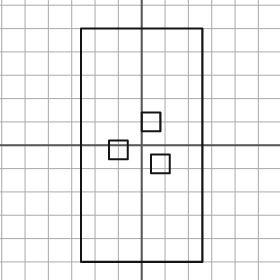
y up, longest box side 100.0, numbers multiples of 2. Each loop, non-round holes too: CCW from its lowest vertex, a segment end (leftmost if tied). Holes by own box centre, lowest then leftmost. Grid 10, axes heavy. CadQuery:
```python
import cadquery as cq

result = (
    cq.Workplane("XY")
    .moveTo(-26.0, -50.0)
    .lineTo(26.0, -50.0)
    .lineTo(26.0, 50.0)
    .lineTo(-26.0, 50.0)
    .close()
    .moveTo(4.0, -12.0)
    .lineTo(12.0, -12.0)
    .lineTo(12.0, -4.0)
    .lineTo(4.0, -4.0)
    .close()
    .moveTo(-14.0, -6.0)
    .lineTo(-6.0, -6.0)
    .lineTo(-6.0, 2.0)
    .lineTo(-14.0, 2.0)
    .close()
    .moveTo(0.0, 6.0)
    .lineTo(8.0, 6.0)
    .lineTo(8.0, 14.0)
    .lineTo(0.0, 14.0)
    .close()
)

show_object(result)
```